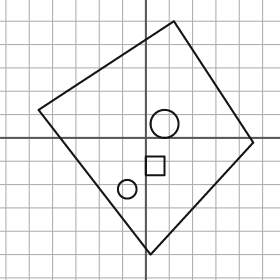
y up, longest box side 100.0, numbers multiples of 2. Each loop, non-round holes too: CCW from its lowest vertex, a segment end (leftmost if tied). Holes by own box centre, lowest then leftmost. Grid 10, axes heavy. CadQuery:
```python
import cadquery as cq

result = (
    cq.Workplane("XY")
    .moveTo(2.0, -50.0)
    .lineTo(46.0, -2.0)
    .lineTo(12.0, 50.0)
    .lineTo(-46.0, 12.0)
    .close()
    .moveTo(-8.0, -22.0)
    .circle(4.0)
    .moveTo(0.0, -16.0)
    .lineTo(8.0, -16.0)
    .lineTo(8.0, -8.0)
    .lineTo(0.0, -8.0)
    .close()
    .moveTo(8.0, 6.0)
    .circle(6.0)
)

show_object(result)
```